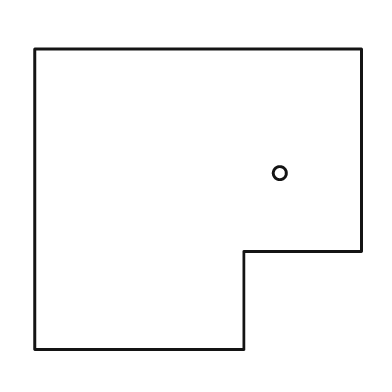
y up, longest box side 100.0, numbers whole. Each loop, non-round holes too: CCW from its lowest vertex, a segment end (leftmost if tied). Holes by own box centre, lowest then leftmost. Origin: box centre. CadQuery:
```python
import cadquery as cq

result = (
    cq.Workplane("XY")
    .moveTo(-50.0, -46.0)
    .lineTo(14.0, -46.0)
    .lineTo(14.0, -16.0)
    .lineTo(50.0, -16.0)
    .lineTo(50.0, 46.0)
    .lineTo(-50.0, 46.0)
    .close()
    .moveTo(25.0, 8.0)
    .circle(2.0)
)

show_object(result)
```